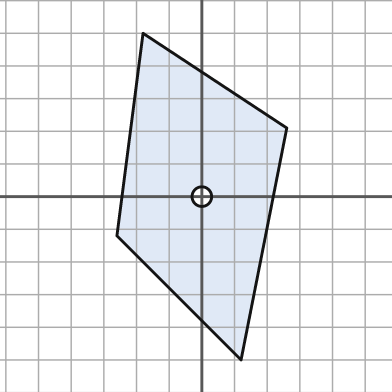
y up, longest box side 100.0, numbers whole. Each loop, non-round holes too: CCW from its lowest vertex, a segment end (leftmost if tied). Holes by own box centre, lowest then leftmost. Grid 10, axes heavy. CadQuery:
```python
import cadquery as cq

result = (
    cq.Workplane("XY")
    .moveTo(12.0, -50.0)
    .lineTo(26.0, 21.0)
    .lineTo(-18.0, 50.0)
    .lineTo(-26.0, -12.0)
    .close()
    .moveTo(0.0, 0.0)
    .circle(3.0)
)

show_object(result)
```